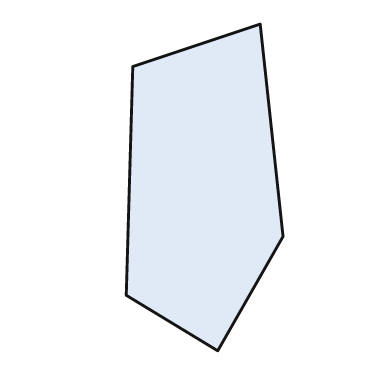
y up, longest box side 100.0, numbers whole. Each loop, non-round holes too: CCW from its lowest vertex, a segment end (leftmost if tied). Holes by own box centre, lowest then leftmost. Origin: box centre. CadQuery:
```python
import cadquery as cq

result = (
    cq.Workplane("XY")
    .moveTo(4.0, -50.0)
    .lineTo(24.0, -15.0)
    .lineTo(17.0, 50.0)
    .lineTo(-22.0, 37.0)
    .lineTo(-24.0, -33.0)
    .close()
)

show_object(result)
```